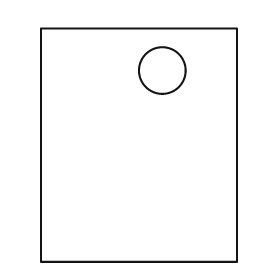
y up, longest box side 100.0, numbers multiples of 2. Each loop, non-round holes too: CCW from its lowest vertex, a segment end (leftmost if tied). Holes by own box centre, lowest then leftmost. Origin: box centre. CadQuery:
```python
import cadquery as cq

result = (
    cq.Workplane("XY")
    .moveTo(-42.0, -50.0)
    .lineTo(42.0, -50.0)
    .lineTo(42.0, 50.0)
    .lineTo(-42.0, 50.0)
    .close()
    .moveTo(10.0, 32.0)
    .circle(10.0)
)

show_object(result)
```